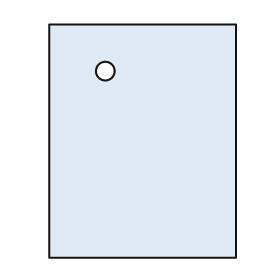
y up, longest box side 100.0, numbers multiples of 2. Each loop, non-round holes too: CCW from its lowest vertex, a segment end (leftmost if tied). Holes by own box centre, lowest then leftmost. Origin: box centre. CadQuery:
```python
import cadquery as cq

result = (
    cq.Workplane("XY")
    .moveTo(-40.0, -50.0)
    .lineTo(40.0, -50.0)
    .lineTo(40.0, 50.0)
    .lineTo(-40.0, 50.0)
    .close()
    .moveTo(-16.0, 30.0)
    .circle(4.0)
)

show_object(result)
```